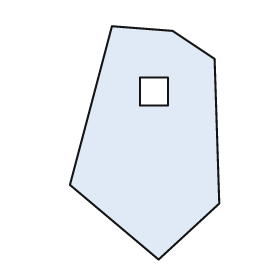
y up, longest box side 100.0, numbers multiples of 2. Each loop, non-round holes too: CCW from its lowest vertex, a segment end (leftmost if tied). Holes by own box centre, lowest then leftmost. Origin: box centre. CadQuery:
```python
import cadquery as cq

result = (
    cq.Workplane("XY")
    .moveTo(6.0, -50.0)
    .lineTo(32.0, -26.0)
    .lineTo(30.0, 36.0)
    .lineTo(12.0, 48.0)
    .lineTo(-14.0, 50.0)
    .lineTo(-32.0, -18.0)
    .close()
    .moveTo(-2.0, 16.0)
    .lineTo(10.0, 16.0)
    .lineTo(10.0, 28.0)
    .lineTo(-2.0, 28.0)
    .close()
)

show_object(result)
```